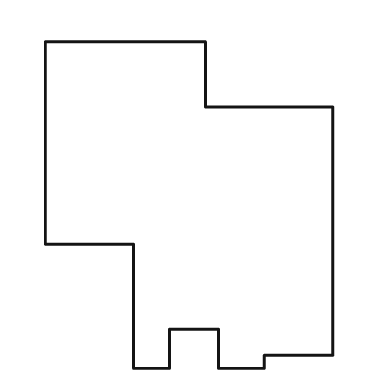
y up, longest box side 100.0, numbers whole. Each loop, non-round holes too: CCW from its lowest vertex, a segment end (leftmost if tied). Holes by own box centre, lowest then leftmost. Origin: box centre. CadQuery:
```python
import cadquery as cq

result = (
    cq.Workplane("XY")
    .moveTo(-17.0, -50.0)
    .lineTo(-6.0, -50.0)
    .lineTo(-6.0, -38.0)
    .lineTo(9.0, -38.0)
    .lineTo(9.0, -50.0)
    .lineTo(23.0, -50.0)
    .lineTo(23.0, -46.0)
    .lineTo(44.0, -46.0)
    .lineTo(44.0, 30.0)
    .lineTo(5.0, 30.0)
    .lineTo(5.0, 50.0)
    .lineTo(-44.0, 50.0)
    .lineTo(-44.0, -12.0)
    .lineTo(-17.0, -12.0)
    .close()
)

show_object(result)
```